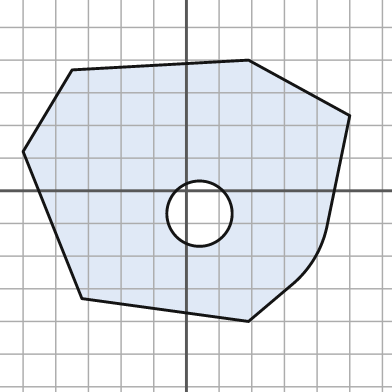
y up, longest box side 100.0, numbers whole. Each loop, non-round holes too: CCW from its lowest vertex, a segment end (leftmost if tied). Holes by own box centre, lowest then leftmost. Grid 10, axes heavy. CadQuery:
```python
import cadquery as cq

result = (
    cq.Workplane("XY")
    .moveTo(19.0, -40.0)
    .lineTo(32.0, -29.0)
    .threePointArc((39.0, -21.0), (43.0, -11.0))
    .lineTo(50.0, 23.0)
    .lineTo(19.0, 40.0)
    .lineTo(-35.0, 37.0)
    .lineTo(-50.0, 12.0)
    .lineTo(-32.0, -33.0)
    .close()
    .moveTo(4.0, -7.0)
    .circle(10.0)
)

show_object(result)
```